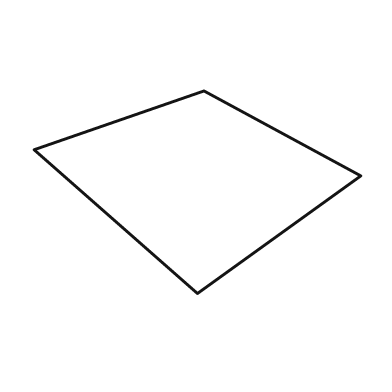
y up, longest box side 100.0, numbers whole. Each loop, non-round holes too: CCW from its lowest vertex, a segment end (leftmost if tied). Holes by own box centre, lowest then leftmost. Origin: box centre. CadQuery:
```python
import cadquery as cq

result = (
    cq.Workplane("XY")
    .moveTo(0.0, -31.0)
    .lineTo(50.0, 5.0)
    .lineTo(2.0, 31.0)
    .lineTo(-50.0, 13.0)
    .close()
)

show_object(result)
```